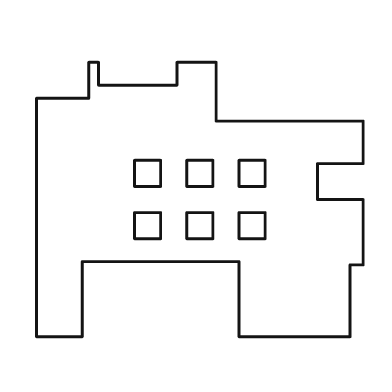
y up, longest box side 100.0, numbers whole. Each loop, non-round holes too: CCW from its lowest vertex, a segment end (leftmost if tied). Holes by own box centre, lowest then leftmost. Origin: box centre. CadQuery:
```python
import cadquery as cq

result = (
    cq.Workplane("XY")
    .moveTo(-50.0, -42.0)
    .lineTo(-36.0, -42.0)
    .lineTo(-36.0, -19.0)
    .lineTo(12.0, -19.0)
    .lineTo(12.0, -42.0)
    .lineTo(46.0, -42.0)
    .lineTo(46.0, -20.0)
    .lineTo(50.0, -20.0)
    .lineTo(50.0, 0.0)
    .lineTo(36.0, 0.0)
    .lineTo(36.0, 11.0)
    .lineTo(50.0, 11.0)
    .lineTo(50.0, 24.0)
    .lineTo(5.0, 24.0)
    .lineTo(5.0, 42.0)
    .lineTo(-7.0, 42.0)
    .lineTo(-7.0, 35.0)
    .lineTo(-31.0, 35.0)
    .lineTo(-31.0, 42.0)
    .lineTo(-34.0, 42.0)
    .lineTo(-34.0, 31.0)
    .lineTo(-50.0, 31.0)
    .close()
    .moveTo(-20.0, -12.0)
    .lineTo(-12.0, -12.0)
    .lineTo(-12.0, -4.0)
    .lineTo(-20.0, -4.0)
    .close()
    .moveTo(-4.0, -12.0)
    .lineTo(4.0, -12.0)
    .lineTo(4.0, -4.0)
    .lineTo(-4.0, -4.0)
    .close()
    .moveTo(12.0, -12.0)
    .lineTo(20.0, -12.0)
    .lineTo(20.0, -4.0)
    .lineTo(12.0, -4.0)
    .close()
    .moveTo(-20.0, 4.0)
    .lineTo(-12.0, 4.0)
    .lineTo(-12.0, 12.0)
    .lineTo(-20.0, 12.0)
    .close()
    .moveTo(-4.0, 4.0)
    .lineTo(4.0, 4.0)
    .lineTo(4.0, 12.0)
    .lineTo(-4.0, 12.0)
    .close()
    .moveTo(12.0, 4.0)
    .lineTo(20.0, 4.0)
    .lineTo(20.0, 12.0)
    .lineTo(12.0, 12.0)
    .close()
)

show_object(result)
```